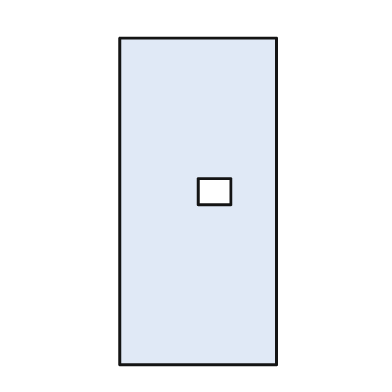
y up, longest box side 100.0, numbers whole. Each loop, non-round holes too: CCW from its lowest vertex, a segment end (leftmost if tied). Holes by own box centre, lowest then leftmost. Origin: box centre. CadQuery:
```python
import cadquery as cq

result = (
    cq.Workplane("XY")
    .moveTo(-24.0, -50.0)
    .lineTo(24.0, -50.0)
    .lineTo(24.0, 50.0)
    .lineTo(-24.0, 50.0)
    .close()
    .moveTo(0.0, -1.0)
    .lineTo(10.0, -1.0)
    .lineTo(10.0, 7.0)
    .lineTo(0.0, 7.0)
    .close()
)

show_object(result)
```